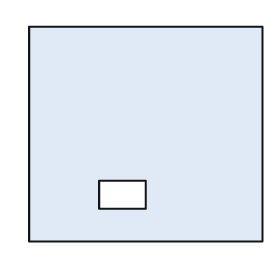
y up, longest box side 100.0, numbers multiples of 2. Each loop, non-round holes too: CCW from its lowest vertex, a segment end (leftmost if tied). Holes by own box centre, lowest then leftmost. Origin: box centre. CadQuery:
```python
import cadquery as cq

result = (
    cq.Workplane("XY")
    .moveTo(-50.0, -46.0)
    .lineTo(50.0, -46.0)
    .lineTo(50.0, 46.0)
    .lineTo(-50.0, 46.0)
    .close()
    .moveTo(-20.0, -32.0)
    .lineTo(0.0, -32.0)
    .lineTo(0.0, -20.0)
    .lineTo(-20.0, -20.0)
    .close()
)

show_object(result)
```